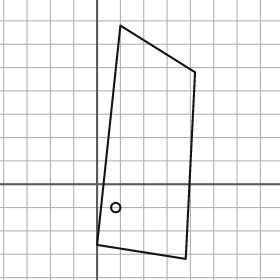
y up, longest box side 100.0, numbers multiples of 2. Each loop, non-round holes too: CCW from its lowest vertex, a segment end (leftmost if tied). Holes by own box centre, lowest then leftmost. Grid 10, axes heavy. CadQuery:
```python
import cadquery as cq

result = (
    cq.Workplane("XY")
    .moveTo(38.0, -32.0)
    .lineTo(42.0, 48.0)
    .lineTo(10.0, 68.0)
    .lineTo(0.0, -26.0)
    .close()
    .moveTo(8.0, -10.0)
    .circle(2.0)
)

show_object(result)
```